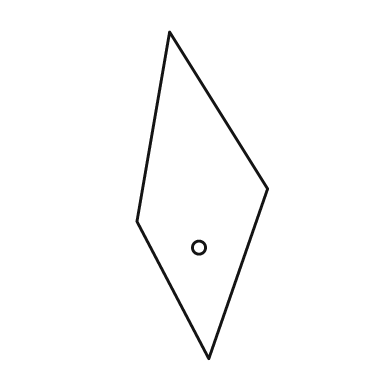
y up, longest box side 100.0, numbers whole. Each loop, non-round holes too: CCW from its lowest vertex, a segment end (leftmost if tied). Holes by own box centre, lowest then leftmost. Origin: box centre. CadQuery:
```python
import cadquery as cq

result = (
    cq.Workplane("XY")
    .moveTo(2.0, -50.0)
    .lineTo(20.0, 2.0)
    .lineTo(-10.0, 50.0)
    .lineTo(-20.0, -8.0)
    .close()
    .moveTo(-1.0, -16.0)
    .circle(2.0)
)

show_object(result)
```